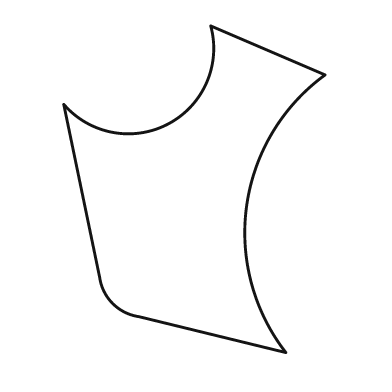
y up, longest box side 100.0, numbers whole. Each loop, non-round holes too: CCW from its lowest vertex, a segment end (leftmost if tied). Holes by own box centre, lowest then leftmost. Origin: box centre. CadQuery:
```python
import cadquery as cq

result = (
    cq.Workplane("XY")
    .moveTo(28.0, -50.0)
    .threePointArc((16.0, -5.0), (40.0, 35.0))
    .lineTo(5.0, 50.0)
    .threePointArc((-8.0, 20.0), (-40.0, 26.0))
    .lineTo(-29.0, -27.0)
    .threePointArc((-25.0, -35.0), (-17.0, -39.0))
    .close()
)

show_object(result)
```